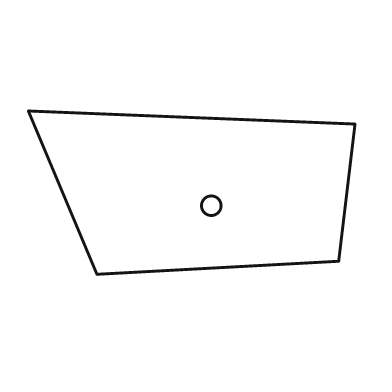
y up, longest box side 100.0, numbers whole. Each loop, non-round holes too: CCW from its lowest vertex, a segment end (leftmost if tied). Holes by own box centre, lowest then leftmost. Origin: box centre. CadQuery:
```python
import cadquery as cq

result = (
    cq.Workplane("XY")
    .moveTo(-29.0, -25.0)
    .lineTo(45.0, -21.0)
    .lineTo(50.0, 21.0)
    .lineTo(-50.0, 25.0)
    .close()
    .moveTo(6.0, -4.0)
    .circle(3.0)
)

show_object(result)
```